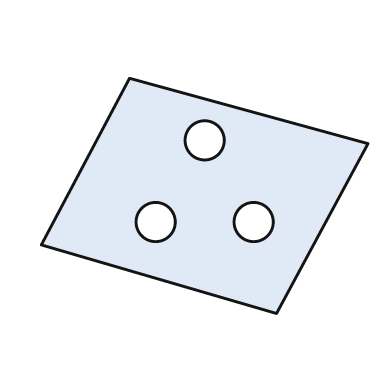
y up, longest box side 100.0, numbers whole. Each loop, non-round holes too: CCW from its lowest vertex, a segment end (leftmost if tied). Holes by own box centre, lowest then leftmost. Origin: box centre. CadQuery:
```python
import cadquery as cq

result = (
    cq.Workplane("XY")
    .moveTo(22.0, -36.0)
    .lineTo(50.0, 16.0)
    .lineTo(-23.0, 36.0)
    .lineTo(-50.0, -15.0)
    .close()
    .moveTo(-15.0, -8.0)
    .circle(6.0)
    .moveTo(15.0, -8.0)
    .circle(6.0)
    .moveTo(0.0, 17.0)
    .circle(6.0)
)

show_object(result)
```